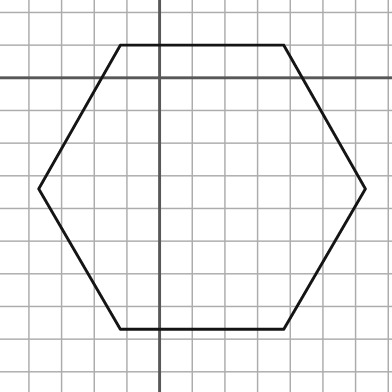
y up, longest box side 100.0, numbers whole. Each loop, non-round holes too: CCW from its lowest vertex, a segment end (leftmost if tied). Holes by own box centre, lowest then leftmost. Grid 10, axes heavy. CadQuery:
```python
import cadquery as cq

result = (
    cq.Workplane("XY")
    .moveTo(-12.0, -77.0)
    .lineTo(38.0, -77.0)
    .lineTo(63.0, -34.0)
    .lineTo(38.0, 10.0)
    .lineTo(-12.0, 10.0)
    .lineTo(-37.0, -34.0)
    .close()
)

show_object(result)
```